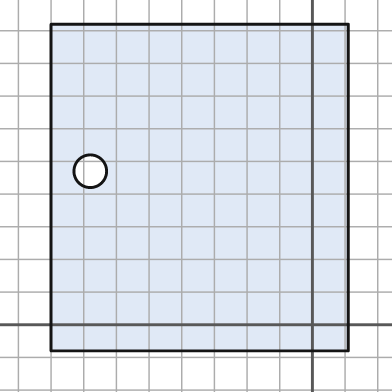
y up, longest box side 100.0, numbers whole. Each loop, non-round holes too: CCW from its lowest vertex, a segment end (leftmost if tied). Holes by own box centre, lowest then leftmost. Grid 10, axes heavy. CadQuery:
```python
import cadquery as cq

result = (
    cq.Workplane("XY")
    .moveTo(-80.0, -8.0)
    .lineTo(11.0, -8.0)
    .lineTo(11.0, 92.0)
    .lineTo(-80.0, 92.0)
    .close()
    .moveTo(-68.0, 47.0)
    .circle(5.0)
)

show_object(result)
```